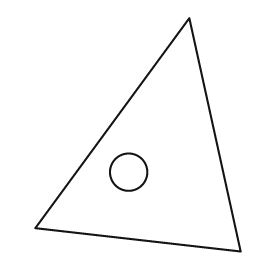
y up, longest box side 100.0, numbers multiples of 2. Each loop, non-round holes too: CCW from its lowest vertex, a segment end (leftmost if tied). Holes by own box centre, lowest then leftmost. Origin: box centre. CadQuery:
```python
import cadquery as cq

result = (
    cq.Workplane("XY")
    .moveTo(44.0, -50.0)
    .lineTo(22.0, 50.0)
    .lineTo(-44.0, -40.0)
    .close()
    .moveTo(-4.0, -16.0)
    .circle(8.0)
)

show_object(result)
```